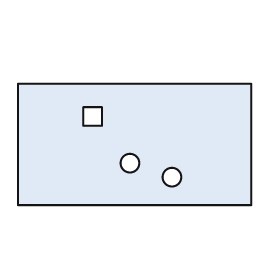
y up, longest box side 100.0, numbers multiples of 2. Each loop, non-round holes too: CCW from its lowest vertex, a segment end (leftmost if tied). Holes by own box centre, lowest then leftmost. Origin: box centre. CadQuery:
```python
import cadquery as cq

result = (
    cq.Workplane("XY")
    .moveTo(-50.0, -26.0)
    .lineTo(50.0, -26.0)
    .lineTo(50.0, 26.0)
    .lineTo(-50.0, 26.0)
    .close()
    .moveTo(16.0, -14.0)
    .circle(4.0)
    .moveTo(-2.0, -8.0)
    .circle(4.0)
    .moveTo(-22.0, 8.0)
    .lineTo(-14.0, 8.0)
    .lineTo(-14.0, 16.0)
    .lineTo(-22.0, 16.0)
    .close()
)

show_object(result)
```